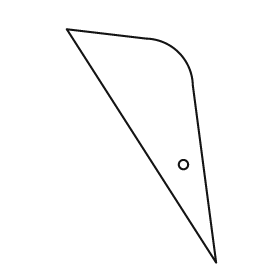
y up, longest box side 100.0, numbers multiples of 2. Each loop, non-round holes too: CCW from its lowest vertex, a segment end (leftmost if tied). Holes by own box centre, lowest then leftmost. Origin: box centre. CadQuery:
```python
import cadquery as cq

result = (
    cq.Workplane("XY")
    .moveTo(32.0, -50.0)
    .lineTo(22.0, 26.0)
    .threePointArc((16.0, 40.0), (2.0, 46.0))
    .lineTo(-32.0, 50.0)
    .close()
    .moveTo(18.0, -8.0)
    .circle(2.0)
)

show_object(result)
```